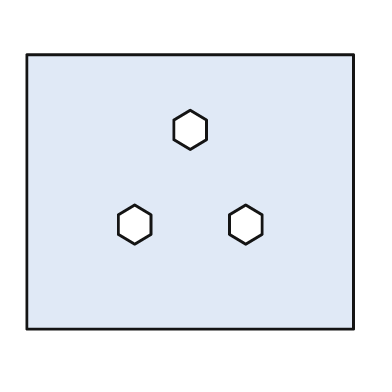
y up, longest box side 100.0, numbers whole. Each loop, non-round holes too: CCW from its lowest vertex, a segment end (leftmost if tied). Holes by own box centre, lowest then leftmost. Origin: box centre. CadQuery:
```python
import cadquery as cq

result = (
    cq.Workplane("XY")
    .moveTo(-50.0, -42.0)
    .lineTo(50.0, -42.0)
    .lineTo(50.0, 42.0)
    .lineTo(-50.0, 42.0)
    .close()
    .moveTo(-17.0, -16.0)
    .lineTo(-12.0, -13.0)
    .lineTo(-12.0, -7.0)
    .lineTo(-17.0, -4.0)
    .lineTo(-22.0, -7.0)
    .lineTo(-22.0, -13.0)
    .close()
    .moveTo(17.0, -16.0)
    .lineTo(22.0, -13.0)
    .lineTo(22.0, -7.0)
    .lineTo(17.0, -4.0)
    .lineTo(12.0, -7.0)
    .lineTo(12.0, -13.0)
    .close()
    .moveTo(0.0, 13.0)
    .lineTo(5.0, 16.0)
    .lineTo(5.0, 22.0)
    .lineTo(0.0, 25.0)
    .lineTo(-5.0, 22.0)
    .lineTo(-5.0, 16.0)
    .close()
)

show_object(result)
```